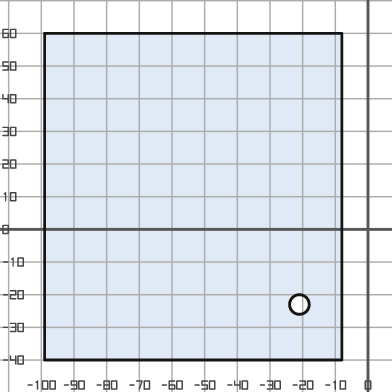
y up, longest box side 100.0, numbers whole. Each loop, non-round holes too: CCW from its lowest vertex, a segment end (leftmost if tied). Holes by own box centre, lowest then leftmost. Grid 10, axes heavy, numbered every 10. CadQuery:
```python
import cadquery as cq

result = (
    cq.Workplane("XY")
    .moveTo(-99.0, -40.0)
    .lineTo(-8.0, -40.0)
    .lineTo(-8.0, 60.0)
    .lineTo(-99.0, 60.0)
    .close()
    .moveTo(-21.0, -23.0)
    .circle(3.0)
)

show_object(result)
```